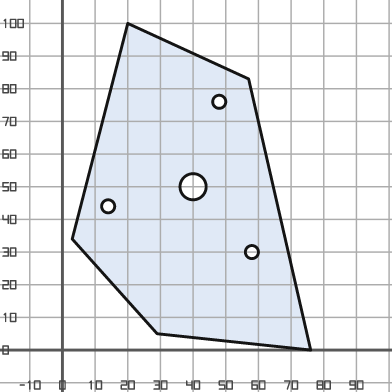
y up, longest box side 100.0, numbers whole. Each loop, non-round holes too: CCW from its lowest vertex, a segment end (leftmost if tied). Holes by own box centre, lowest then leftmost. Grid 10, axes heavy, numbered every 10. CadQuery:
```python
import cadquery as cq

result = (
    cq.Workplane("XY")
    .moveTo(76.0, 0.0)
    .lineTo(57.0, 83.0)
    .lineTo(20.0, 100.0)
    .lineTo(3.0, 34.0)
    .lineTo(29.0, 5.0)
    .close()
    .moveTo(58.0, 30.0)
    .circle(2.0)
    .moveTo(14.0, 44.0)
    .circle(2.0)
    .moveTo(40.0, 50.0)
    .circle(4.0)
    .moveTo(48.0, 76.0)
    .circle(2.0)
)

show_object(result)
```